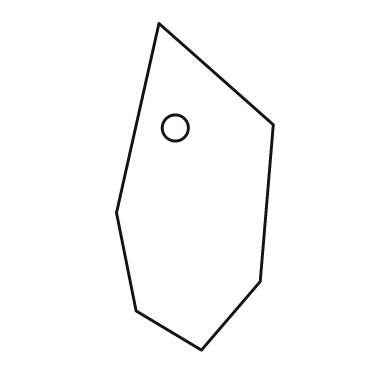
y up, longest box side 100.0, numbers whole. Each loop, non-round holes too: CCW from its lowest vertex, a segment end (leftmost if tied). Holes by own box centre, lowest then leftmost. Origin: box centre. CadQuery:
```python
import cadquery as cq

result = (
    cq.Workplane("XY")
    .moveTo(2.0, -50.0)
    .lineTo(20.0, -29.0)
    .lineTo(24.0, 19.0)
    .lineTo(-11.0, 50.0)
    .lineTo(-24.0, -8.0)
    .lineTo(-18.0, -38.0)
    .close()
    .moveTo(-6.0, 18.0)
    .circle(4.0)
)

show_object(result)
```